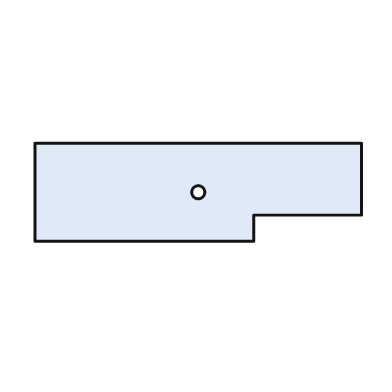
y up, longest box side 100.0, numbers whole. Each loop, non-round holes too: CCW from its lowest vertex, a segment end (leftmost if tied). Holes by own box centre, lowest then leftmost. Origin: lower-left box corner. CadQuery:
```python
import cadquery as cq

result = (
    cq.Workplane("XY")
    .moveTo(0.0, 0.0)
    .lineTo(67.0, 0.0)
    .lineTo(67.0, 8.0)
    .lineTo(100.0, 8.0)
    .lineTo(100.0, 30.0)
    .lineTo(0.0, 30.0)
    .close()
    .moveTo(50.0, 15.0)
    .circle(2.0)
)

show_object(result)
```